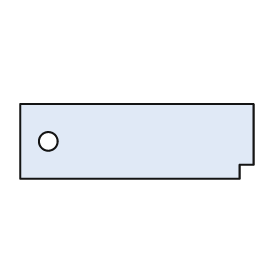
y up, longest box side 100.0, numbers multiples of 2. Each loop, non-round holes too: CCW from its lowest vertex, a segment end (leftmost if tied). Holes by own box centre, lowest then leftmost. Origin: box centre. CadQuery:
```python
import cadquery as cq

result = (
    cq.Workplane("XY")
    .moveTo(-50.0, -16.0)
    .lineTo(44.0, -16.0)
    .lineTo(44.0, -10.0)
    .lineTo(50.0, -10.0)
    .lineTo(50.0, 16.0)
    .lineTo(-50.0, 16.0)
    .close()
    .moveTo(-38.0, 0.0)
    .circle(4.0)
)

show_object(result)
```